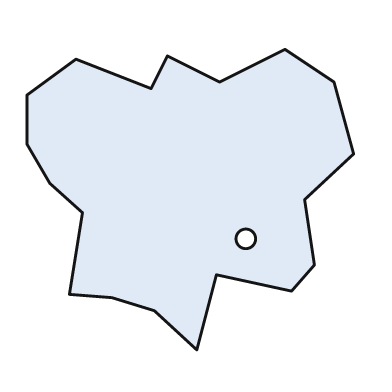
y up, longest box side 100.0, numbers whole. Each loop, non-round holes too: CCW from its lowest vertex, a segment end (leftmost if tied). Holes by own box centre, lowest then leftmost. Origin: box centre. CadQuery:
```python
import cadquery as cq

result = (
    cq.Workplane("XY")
    .moveTo(2.0, -46.0)
    .lineTo(8.0, -23.0)
    .lineTo(31.0, -28.0)
    .lineTo(38.0, -20.0)
    .lineTo(35.0, 0.0)
    .lineTo(50.0, 14.0)
    .lineTo(44.0, 36.0)
    .lineTo(29.0, 46.0)
    .lineTo(9.0, 36.0)
    .lineTo(-7.0, 44.0)
    .lineTo(-12.0, 34.0)
    .lineTo(-35.0, 43.0)
    .lineTo(-50.0, 32.0)
    .lineTo(-50.0, 17.0)
    .lineTo(-43.0, 5.0)
    .lineTo(-33.0, -4.0)
    .lineTo(-37.0, -29.0)
    .lineTo(-24.0, -30.0)
    .lineTo(-11.0, -34.0)
    .close()
    .moveTo(17.0, -12.0)
    .circle(3.0)
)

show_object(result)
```